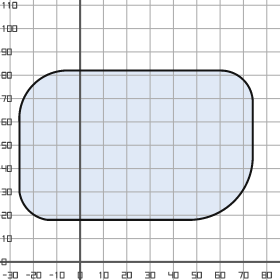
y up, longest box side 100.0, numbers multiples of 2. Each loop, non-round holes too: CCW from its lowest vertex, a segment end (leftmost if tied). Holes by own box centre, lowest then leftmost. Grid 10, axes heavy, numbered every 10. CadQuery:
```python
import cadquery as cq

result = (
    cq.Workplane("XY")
    .moveTo(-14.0, 18.0)
    .lineTo(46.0, 18.0)
    .threePointArc((66.0, 26.0), (74.0, 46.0))
    .lineTo(74.0, 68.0)
    .threePointArc((70.0, 78.0), (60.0, 82.0))
    .lineTo(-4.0, 82.0)
    .threePointArc((-20.0, 76.0), (-26.0, 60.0))
    .lineTo(-26.0, 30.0)
    .threePointArc((-22.0, 22.0), (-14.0, 18.0))
    .close()
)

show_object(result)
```